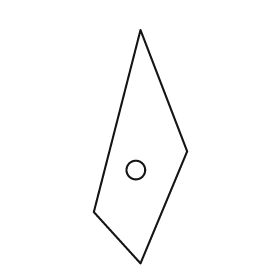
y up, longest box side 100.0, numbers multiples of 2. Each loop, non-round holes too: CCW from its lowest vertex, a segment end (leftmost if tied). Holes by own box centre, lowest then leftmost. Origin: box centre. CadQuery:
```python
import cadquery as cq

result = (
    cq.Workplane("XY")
    .moveTo(0.0, -50.0)
    .lineTo(20.0, -2.0)
    .lineTo(0.0, 50.0)
    .lineTo(-20.0, -28.0)
    .close()
    .moveTo(-2.0, -10.0)
    .circle(4.0)
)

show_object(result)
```